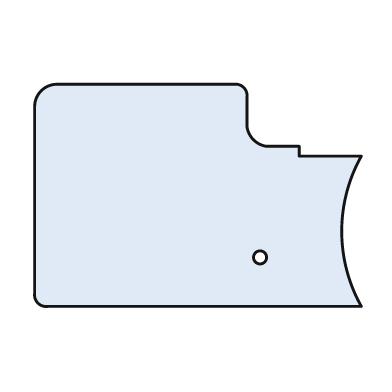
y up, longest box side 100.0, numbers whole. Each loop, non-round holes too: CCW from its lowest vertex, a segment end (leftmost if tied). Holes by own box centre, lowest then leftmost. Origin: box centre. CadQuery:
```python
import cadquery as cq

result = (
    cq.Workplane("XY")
    .moveTo(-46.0, -34.0)
    .lineTo(50.0, -34.0)
    .threePointArc((44.0, -11.0), (50.0, 12.0))
    .lineTo(31.0, 12.0)
    .lineTo(31.0, 15.0)
    .lineTo(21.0, 15.0)
    .threePointArc((17.0, 17.0), (15.0, 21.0))
    .lineTo(15.0, 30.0)
    .threePointArc((14.0, 33.0), (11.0, 34.0))
    .lineTo(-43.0, 34.0)
    .threePointArc((-48.0, 32.0), (-50.0, 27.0))
    .lineTo(-50.0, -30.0)
    .threePointArc((-49.0, -33.0), (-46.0, -34.0))
    .close()
    .moveTo(19.0, -19.0)
    .circle(2.0)
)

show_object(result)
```